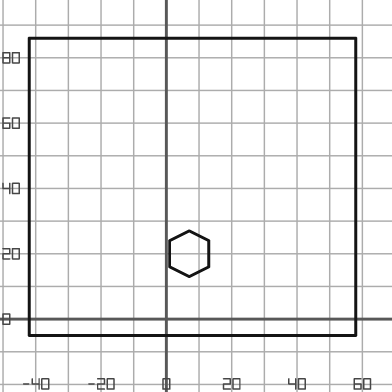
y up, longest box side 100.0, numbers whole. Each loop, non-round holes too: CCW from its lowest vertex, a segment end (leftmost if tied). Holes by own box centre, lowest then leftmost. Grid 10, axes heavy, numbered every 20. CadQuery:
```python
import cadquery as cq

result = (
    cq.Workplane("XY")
    .moveTo(-42.0, -5.0)
    .lineTo(58.0, -5.0)
    .lineTo(58.0, 86.0)
    .lineTo(-42.0, 86.0)
    .close()
    .moveTo(7.0, 13.0)
    .lineTo(13.0, 16.0)
    .lineTo(13.0, 24.0)
    .lineTo(7.0, 27.0)
    .lineTo(1.0, 24.0)
    .lineTo(1.0, 16.0)
    .close()
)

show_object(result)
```